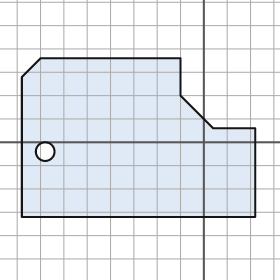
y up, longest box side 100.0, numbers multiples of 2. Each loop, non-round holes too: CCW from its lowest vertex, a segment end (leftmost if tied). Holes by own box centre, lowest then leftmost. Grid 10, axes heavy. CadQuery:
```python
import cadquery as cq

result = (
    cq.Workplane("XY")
    .moveTo(-78.0, -32.0)
    .lineTo(22.0, -32.0)
    .lineTo(22.0, 6.0)
    .lineTo(4.0, 6.0)
    .lineTo(-10.0, 20.0)
    .lineTo(-10.0, 36.0)
    .lineTo(-70.0, 36.0)
    .lineTo(-78.0, 28.0)
    .close()
    .moveTo(-68.0, -4.0)
    .circle(4.0)
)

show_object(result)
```